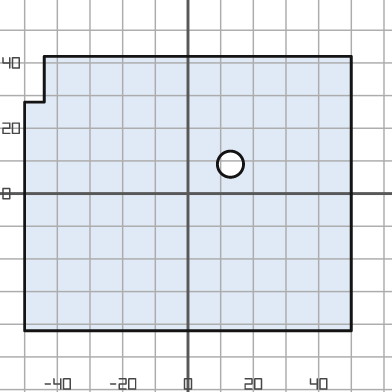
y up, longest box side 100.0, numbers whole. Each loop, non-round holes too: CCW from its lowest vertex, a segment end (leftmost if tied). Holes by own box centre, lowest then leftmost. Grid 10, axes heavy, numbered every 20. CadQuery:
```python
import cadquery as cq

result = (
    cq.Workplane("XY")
    .moveTo(-50.0, -42.0)
    .lineTo(50.0, -42.0)
    .lineTo(50.0, 42.0)
    .lineTo(-44.0, 42.0)
    .lineTo(-44.0, 28.0)
    .lineTo(-50.0, 28.0)
    .close()
    .moveTo(13.0, 9.0)
    .circle(4.0)
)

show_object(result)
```